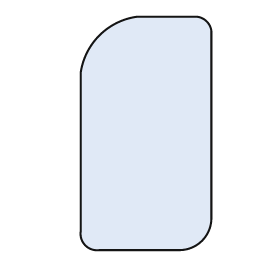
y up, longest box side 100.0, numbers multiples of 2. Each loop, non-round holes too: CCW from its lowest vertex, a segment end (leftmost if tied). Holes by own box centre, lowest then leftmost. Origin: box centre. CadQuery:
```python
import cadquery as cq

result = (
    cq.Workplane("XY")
    .moveTo(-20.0, -50.0)
    .lineTo(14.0, -50.0)
    .threePointArc((24.0, -46.0), (28.0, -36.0))
    .lineTo(28.0, 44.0)
    .threePointArc((26.0, 48.0), (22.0, 50.0))
    .lineTo(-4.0, 50.0)
    .threePointArc((-20.0, 42.0), (-28.0, 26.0))
    .lineTo(-28.0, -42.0)
    .threePointArc((-26.0, -48.0), (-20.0, -50.0))
    .close()
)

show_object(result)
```